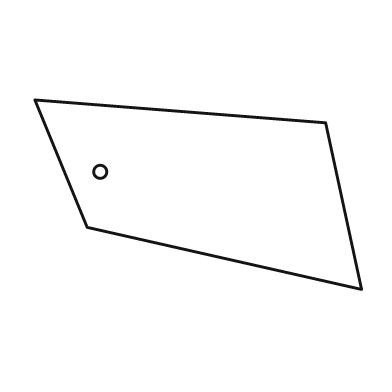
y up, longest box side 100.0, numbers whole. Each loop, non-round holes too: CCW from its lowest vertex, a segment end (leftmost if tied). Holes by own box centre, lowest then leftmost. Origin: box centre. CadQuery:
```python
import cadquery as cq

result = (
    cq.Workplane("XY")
    .moveTo(50.0, -29.0)
    .lineTo(39.0, 22.0)
    .lineTo(-50.0, 29.0)
    .lineTo(-34.0, -10.0)
    .close()
    .moveTo(-30.0, 7.0)
    .circle(2.0)
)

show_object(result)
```